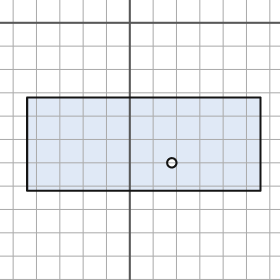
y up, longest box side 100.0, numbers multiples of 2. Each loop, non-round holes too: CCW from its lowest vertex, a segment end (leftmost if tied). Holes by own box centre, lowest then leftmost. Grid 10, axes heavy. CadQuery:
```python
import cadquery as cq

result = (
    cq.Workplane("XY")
    .moveTo(-44.0, -72.0)
    .lineTo(56.0, -72.0)
    .lineTo(56.0, -32.0)
    .lineTo(-44.0, -32.0)
    .close()
    .moveTo(18.0, -60.0)
    .circle(2.0)
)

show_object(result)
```